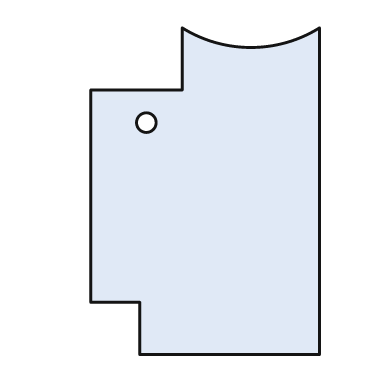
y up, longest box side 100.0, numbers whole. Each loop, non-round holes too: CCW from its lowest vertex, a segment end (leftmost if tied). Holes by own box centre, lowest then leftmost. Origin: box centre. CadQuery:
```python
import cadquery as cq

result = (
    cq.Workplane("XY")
    .moveTo(-20.0, -50.0)
    .lineTo(35.0, -50.0)
    .lineTo(35.0, 50.0)
    .threePointArc((14.0, 44.0), (-7.0, 50.0))
    .lineTo(-7.0, 31.0)
    .lineTo(-35.0, 31.0)
    .lineTo(-35.0, -34.0)
    .lineTo(-20.0, -34.0)
    .close()
    .moveTo(-18.0, 21.0)
    .circle(3.0)
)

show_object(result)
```